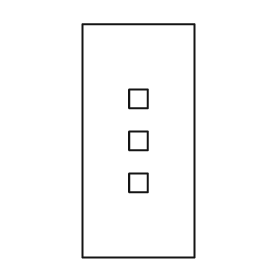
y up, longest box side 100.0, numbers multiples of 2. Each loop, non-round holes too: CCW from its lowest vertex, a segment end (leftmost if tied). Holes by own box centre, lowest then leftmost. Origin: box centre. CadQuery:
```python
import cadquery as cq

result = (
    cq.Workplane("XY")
    .moveTo(-24.0, -50.0)
    .lineTo(24.0, -50.0)
    .lineTo(24.0, 50.0)
    .lineTo(-24.0, 50.0)
    .close()
    .moveTo(-4.0, -22.0)
    .lineTo(4.0, -22.0)
    .lineTo(4.0, -14.0)
    .lineTo(-4.0, -14.0)
    .close()
    .moveTo(-4.0, -4.0)
    .lineTo(4.0, -4.0)
    .lineTo(4.0, 4.0)
    .lineTo(-4.0, 4.0)
    .close()
    .moveTo(-4.0, 14.0)
    .lineTo(4.0, 14.0)
    .lineTo(4.0, 22.0)
    .lineTo(-4.0, 22.0)
    .close()
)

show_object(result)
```